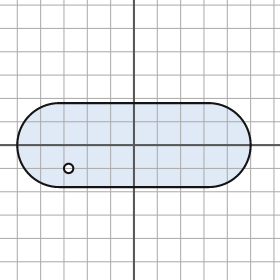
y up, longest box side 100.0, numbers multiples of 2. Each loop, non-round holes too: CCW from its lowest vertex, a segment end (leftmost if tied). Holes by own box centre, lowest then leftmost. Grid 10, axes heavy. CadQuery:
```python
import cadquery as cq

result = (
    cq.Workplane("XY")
    .moveTo(-32.0, -18.0)
    .lineTo(32.0, -18.0)
    .threePointArc((50.0, 0.0), (32.0, 18.0))
    .lineTo(-32.0, 18.0)
    .threePointArc((-50.0, 0.0), (-32.0, -18.0))
    .close()
    .moveTo(-28.0, -10.0)
    .circle(2.0)
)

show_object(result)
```